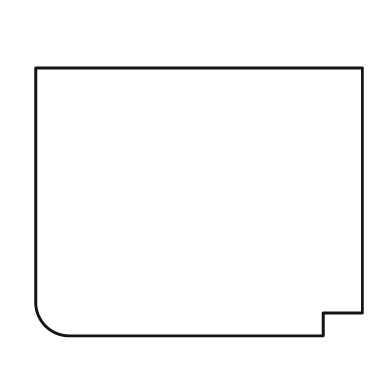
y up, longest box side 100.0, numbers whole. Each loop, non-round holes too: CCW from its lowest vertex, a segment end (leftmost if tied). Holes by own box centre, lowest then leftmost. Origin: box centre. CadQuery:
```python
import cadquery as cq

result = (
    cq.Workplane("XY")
    .moveTo(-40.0, -41.0)
    .lineTo(38.0, -41.0)
    .lineTo(38.0, -34.0)
    .lineTo(50.0, -34.0)
    .lineTo(50.0, 41.0)
    .lineTo(-50.0, 41.0)
    .lineTo(-50.0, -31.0)
    .threePointArc((-47.0, -38.0), (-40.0, -41.0))
    .close()
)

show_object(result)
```